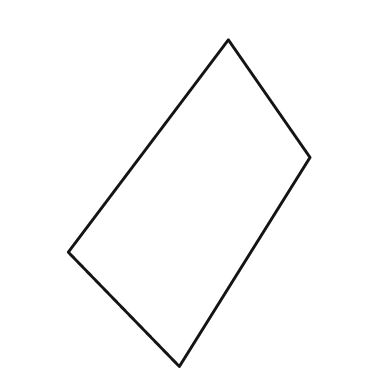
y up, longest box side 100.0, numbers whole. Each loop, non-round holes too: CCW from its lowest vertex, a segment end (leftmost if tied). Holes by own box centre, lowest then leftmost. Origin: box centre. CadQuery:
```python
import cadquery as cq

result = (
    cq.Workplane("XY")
    .moveTo(-3.0, -50.0)
    .lineTo(37.0, 14.0)
    .lineTo(12.0, 50.0)
    .lineTo(-37.0, -15.0)
    .close()
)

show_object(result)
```